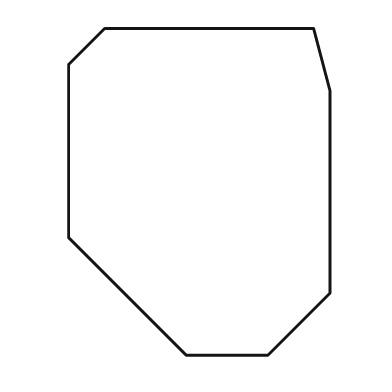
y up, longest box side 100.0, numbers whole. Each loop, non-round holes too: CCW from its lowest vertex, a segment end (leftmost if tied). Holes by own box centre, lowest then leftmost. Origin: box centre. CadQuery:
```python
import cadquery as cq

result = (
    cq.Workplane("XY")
    .moveTo(-4.0, -50.0)
    .lineTo(21.0, -50.0)
    .lineTo(40.0, -31.0)
    .lineTo(40.0, 31.0)
    .lineTo(35.0, 50.0)
    .lineTo(-29.0, 50.0)
    .lineTo(-40.0, 39.0)
    .lineTo(-40.0, -14.0)
    .close()
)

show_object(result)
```